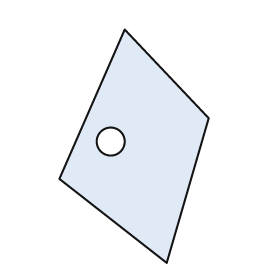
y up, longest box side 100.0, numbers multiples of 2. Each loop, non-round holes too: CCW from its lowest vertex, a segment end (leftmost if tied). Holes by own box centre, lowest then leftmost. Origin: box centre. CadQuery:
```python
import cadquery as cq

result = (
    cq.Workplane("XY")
    .moveTo(14.0, -50.0)
    .lineTo(32.0, 12.0)
    .lineTo(-4.0, 50.0)
    .lineTo(-32.0, -14.0)
    .close()
    .moveTo(-10.0, 2.0)
    .circle(6.0)
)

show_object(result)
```